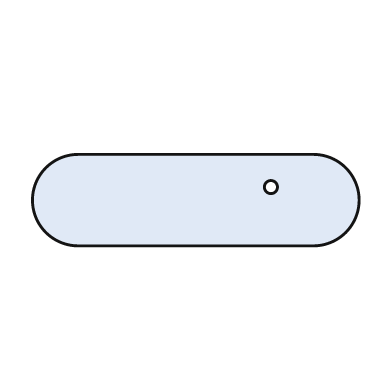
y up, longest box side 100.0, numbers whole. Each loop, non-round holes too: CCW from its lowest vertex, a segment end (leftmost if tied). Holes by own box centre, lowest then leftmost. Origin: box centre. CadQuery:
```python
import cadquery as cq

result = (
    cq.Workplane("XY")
    .moveTo(-36.0, -14.0)
    .lineTo(36.0, -14.0)
    .threePointArc((50.0, 0.0), (36.0, 14.0))
    .lineTo(-36.0, 14.0)
    .threePointArc((-50.0, 0.0), (-36.0, -14.0))
    .close()
    .moveTo(23.0, 4.0)
    .circle(2.0)
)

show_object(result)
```